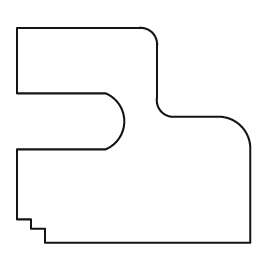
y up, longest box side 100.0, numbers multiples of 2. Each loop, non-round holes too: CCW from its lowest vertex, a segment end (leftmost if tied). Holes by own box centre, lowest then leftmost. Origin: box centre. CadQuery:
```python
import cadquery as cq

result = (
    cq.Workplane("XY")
    .moveTo(-38.0, -46.0)
    .lineTo(50.0, -46.0)
    .lineTo(50.0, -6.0)
    .threePointArc((46.0, 4.0), (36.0, 8.0))
    .lineTo(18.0, 8.0)
    .threePointArc((12.0, 10.0), (10.0, 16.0))
    .lineTo(10.0, 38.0)
    .threePointArc((8.0, 44.0), (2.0, 46.0))
    .lineTo(-50.0, 46.0)
    .lineTo(-50.0, 18.0)
    .lineTo(-12.0, 18.0)
    .threePointArc((-4.0, 6.0), (-12.0, -6.0))
    .lineTo(-50.0, -6.0)
    .lineTo(-50.0, -36.0)
    .lineTo(-44.0, -36.0)
    .lineTo(-44.0, -40.0)
    .lineTo(-38.0, -40.0)
    .close()
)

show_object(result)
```